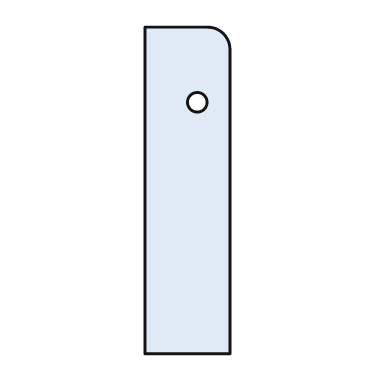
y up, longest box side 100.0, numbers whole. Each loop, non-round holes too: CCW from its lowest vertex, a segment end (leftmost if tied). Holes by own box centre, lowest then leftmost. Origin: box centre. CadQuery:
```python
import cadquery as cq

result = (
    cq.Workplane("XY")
    .moveTo(-13.0, -50.0)
    .lineTo(13.0, -50.0)
    .lineTo(13.0, 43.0)
    .threePointArc((11.0, 48.0), (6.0, 50.0))
    .lineTo(-13.0, 50.0)
    .close()
    .moveTo(3.0, 27.0)
    .circle(3.0)
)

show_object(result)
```